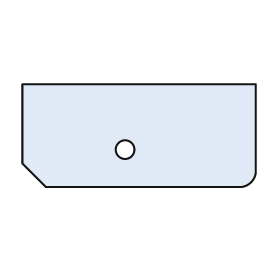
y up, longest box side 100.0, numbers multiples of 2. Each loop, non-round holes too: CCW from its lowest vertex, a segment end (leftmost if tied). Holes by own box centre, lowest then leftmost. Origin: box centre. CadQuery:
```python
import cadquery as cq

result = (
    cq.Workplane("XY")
    .moveTo(-40.0, -22.0)
    .lineTo(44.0, -22.0)
    .threePointArc((48.0, -20.0), (50.0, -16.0))
    .lineTo(50.0, 22.0)
    .lineTo(-50.0, 22.0)
    .lineTo(-50.0, -12.0)
    .close()
    .moveTo(-6.0, -6.0)
    .circle(4.0)
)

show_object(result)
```